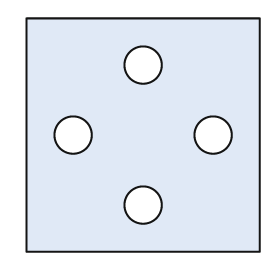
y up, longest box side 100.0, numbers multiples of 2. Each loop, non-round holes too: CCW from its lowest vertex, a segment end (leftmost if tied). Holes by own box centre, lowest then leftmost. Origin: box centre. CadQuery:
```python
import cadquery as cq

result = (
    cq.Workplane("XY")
    .moveTo(-50.0, -50.0)
    .lineTo(50.0, -50.0)
    .lineTo(50.0, 50.0)
    .lineTo(-50.0, 50.0)
    .close()
    .moveTo(0.0, -30.0)
    .circle(8.0)
    .moveTo(-30.0, 0.0)
    .circle(8.0)
    .moveTo(30.0, 0.0)
    .circle(8.0)
    .moveTo(0.0, 30.0)
    .circle(8.0)
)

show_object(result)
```